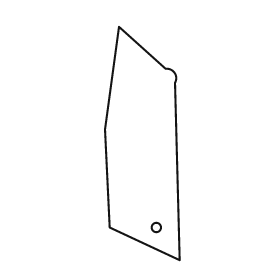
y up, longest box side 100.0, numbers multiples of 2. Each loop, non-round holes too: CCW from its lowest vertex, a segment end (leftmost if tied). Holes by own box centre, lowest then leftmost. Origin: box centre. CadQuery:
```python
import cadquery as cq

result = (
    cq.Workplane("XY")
    .moveTo(16.0, -50.0)
    .lineTo(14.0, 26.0)
    .threePointArc((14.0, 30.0), (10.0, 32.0))
    .lineTo(-10.0, 50.0)
    .lineTo(-16.0, 6.0)
    .lineTo(-14.0, -36.0)
    .close()
    .moveTo(6.0, -36.0)
    .circle(2.0)
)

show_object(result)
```